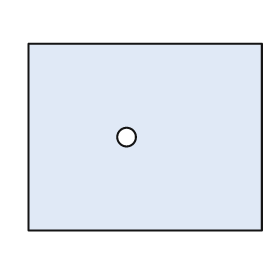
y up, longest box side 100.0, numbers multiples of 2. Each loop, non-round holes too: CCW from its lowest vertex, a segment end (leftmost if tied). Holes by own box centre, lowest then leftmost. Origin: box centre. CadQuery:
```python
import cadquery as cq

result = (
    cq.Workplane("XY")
    .moveTo(-50.0, -40.0)
    .lineTo(50.0, -40.0)
    .lineTo(50.0, 40.0)
    .lineTo(-50.0, 40.0)
    .close()
    .moveTo(-8.0, 0.0)
    .circle(4.0)
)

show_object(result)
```